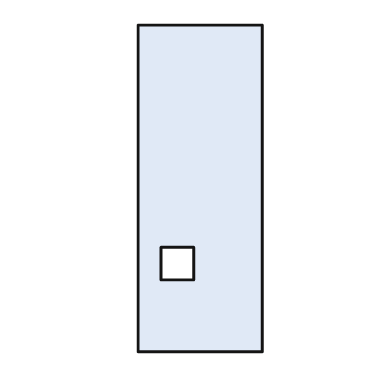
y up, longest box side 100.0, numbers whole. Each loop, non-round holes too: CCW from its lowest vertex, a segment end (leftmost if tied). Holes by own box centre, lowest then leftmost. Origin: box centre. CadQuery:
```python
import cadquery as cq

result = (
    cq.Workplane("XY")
    .moveTo(-19.0, -50.0)
    .lineTo(19.0, -50.0)
    .lineTo(19.0, 50.0)
    .lineTo(-19.0, 50.0)
    .close()
    .moveTo(-12.0, -28.0)
    .lineTo(-2.0, -28.0)
    .lineTo(-2.0, -18.0)
    .lineTo(-12.0, -18.0)
    .close()
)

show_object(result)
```